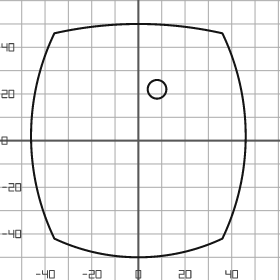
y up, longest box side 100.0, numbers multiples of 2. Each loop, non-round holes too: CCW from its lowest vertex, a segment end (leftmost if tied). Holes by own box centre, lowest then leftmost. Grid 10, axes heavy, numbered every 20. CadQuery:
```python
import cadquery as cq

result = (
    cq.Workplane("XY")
    .moveTo(-36.0, -42.0)
    .threePointArc((0.0, -50.0), (36.0, -42.0))
    .threePointArc((46.0, 2.0), (36.0, 46.0))
    .threePointArc((0.0, 50.0), (-36.0, 46.0))
    .threePointArc((-46.0, 2.0), (-36.0, -42.0))
    .close()
    .moveTo(8.0, 22.0)
    .circle(4.0)
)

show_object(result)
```